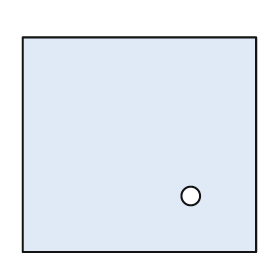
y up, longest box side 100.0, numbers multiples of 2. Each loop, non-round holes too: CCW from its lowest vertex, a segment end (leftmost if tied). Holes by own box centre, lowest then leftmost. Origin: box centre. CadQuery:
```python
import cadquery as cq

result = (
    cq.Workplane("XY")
    .moveTo(-50.0, -46.0)
    .lineTo(50.0, -46.0)
    .lineTo(50.0, 46.0)
    .lineTo(-50.0, 46.0)
    .close()
    .moveTo(22.0, -22.0)
    .circle(4.0)
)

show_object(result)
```